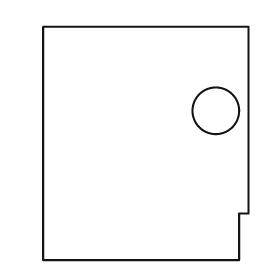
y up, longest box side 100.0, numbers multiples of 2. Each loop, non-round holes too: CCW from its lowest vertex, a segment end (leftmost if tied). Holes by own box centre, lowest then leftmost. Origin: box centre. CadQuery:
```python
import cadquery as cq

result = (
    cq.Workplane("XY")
    .moveTo(-44.0, -50.0)
    .lineTo(40.0, -50.0)
    .lineTo(40.0, -30.0)
    .lineTo(44.0, -30.0)
    .lineTo(44.0, 50.0)
    .lineTo(-44.0, 50.0)
    .close()
    .moveTo(30.0, 14.0)
    .circle(10.0)
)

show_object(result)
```